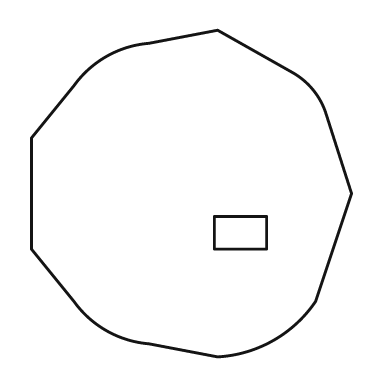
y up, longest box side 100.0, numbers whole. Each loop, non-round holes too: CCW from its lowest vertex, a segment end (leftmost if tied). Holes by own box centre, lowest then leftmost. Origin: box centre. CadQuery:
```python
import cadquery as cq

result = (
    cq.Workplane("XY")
    .moveTo(8.0, -50.0)
    .threePointArc((25.0, -45.0), (38.0, -33.0))
    .lineTo(49.0, 0.0)
    .lineTo(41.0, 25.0)
    .threePointArc((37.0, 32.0), (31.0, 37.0))
    .lineTo(8.0, 50.0)
    .lineTo(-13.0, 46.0)
    .threePointArc((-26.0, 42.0), (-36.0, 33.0))
    .lineTo(-49.0, 17.0)
    .lineTo(-49.0, -17.0)
    .lineTo(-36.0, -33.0)
    .threePointArc((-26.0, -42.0), (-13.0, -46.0))
    .close()
    .moveTo(7.0, -17.0)
    .lineTo(23.0, -17.0)
    .lineTo(23.0, -7.0)
    .lineTo(7.0, -7.0)
    .close()
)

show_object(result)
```